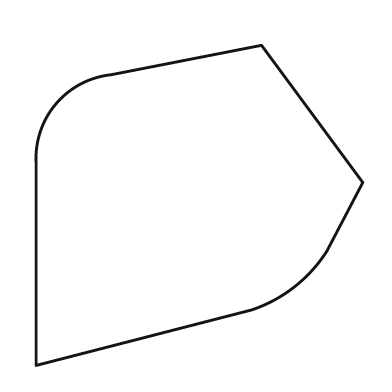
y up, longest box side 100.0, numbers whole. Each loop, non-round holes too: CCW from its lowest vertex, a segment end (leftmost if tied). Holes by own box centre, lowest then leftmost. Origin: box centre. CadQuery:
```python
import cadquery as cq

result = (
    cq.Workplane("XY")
    .moveTo(-50.0, -49.0)
    .lineTo(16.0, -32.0)
    .threePointArc((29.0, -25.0), (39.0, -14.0))
    .lineTo(50.0, 7.0)
    .lineTo(19.0, 49.0)
    .lineTo(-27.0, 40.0)
    .threePointArc((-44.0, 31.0), (-50.0, 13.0))
    .close()
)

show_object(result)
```